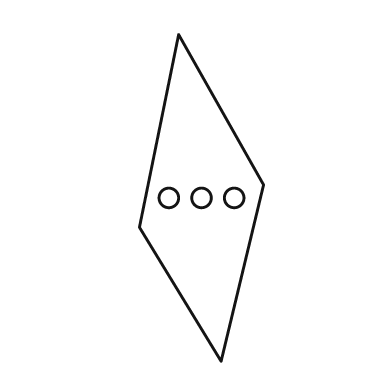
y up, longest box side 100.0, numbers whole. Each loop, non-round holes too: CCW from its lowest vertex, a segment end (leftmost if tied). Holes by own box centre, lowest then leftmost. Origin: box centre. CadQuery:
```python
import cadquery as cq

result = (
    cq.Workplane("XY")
    .moveTo(6.0, -50.0)
    .lineTo(19.0, 4.0)
    .lineTo(-7.0, 50.0)
    .lineTo(-19.0, -9.0)
    .close()
    .moveTo(-10.0, 0.0)
    .circle(3.0)
    .moveTo(0.0, 0.0)
    .circle(3.0)
    .moveTo(10.0, 0.0)
    .circle(3.0)
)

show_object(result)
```